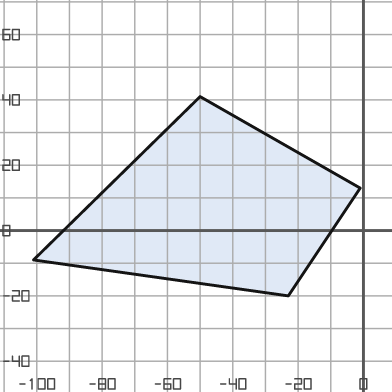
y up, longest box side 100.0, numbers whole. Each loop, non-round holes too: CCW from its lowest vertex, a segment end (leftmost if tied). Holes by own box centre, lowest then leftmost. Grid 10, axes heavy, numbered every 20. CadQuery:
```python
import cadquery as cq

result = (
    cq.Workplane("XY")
    .moveTo(-23.0, -20.0)
    .lineTo(-1.0, 13.0)
    .lineTo(-50.0, 41.0)
    .lineTo(-101.0, -9.0)
    .close()
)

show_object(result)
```